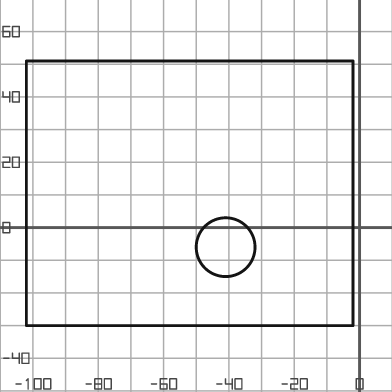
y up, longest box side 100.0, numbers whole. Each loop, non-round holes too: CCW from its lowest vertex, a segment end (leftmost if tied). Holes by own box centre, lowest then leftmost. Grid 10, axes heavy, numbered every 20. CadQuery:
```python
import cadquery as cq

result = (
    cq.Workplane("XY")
    .moveTo(-102.0, -30.0)
    .lineTo(-2.0, -30.0)
    .lineTo(-2.0, 51.0)
    .lineTo(-102.0, 51.0)
    .close()
    .moveTo(-41.0, -6.0)
    .circle(9.0)
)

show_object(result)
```